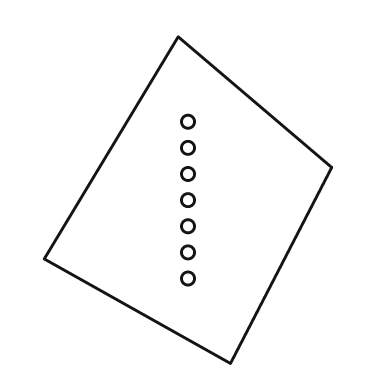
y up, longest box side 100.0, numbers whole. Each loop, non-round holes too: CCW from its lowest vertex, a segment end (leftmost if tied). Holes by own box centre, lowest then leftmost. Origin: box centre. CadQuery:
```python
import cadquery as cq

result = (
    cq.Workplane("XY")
    .moveTo(13.0, -50.0)
    .lineTo(44.0, 10.0)
    .lineTo(-3.0, 50.0)
    .lineTo(-44.0, -18.0)
    .close()
    .moveTo(0.0, -24.0)
    .circle(2.0)
    .moveTo(0.0, -16.0)
    .circle(2.0)
    .moveTo(0.0, -8.0)
    .circle(2.0)
    .moveTo(0.0, 0.0)
    .circle(2.0)
    .moveTo(0.0, 8.0)
    .circle(2.0)
    .moveTo(0.0, 16.0)
    .circle(2.0)
    .moveTo(0.0, 24.0)
    .circle(2.0)
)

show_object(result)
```